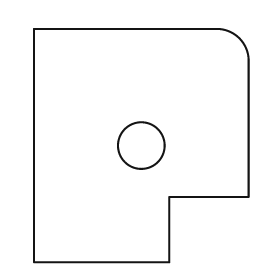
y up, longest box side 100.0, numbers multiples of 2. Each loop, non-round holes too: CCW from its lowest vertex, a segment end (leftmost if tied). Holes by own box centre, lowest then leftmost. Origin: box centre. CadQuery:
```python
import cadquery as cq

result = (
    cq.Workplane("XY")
    .moveTo(-46.0, -50.0)
    .lineTo(12.0, -50.0)
    .lineTo(12.0, -22.0)
    .lineTo(46.0, -22.0)
    .lineTo(46.0, 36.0)
    .threePointArc((42.0, 46.0), (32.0, 50.0))
    .lineTo(-46.0, 50.0)
    .close()
    .moveTo(0.0, 0.0)
    .circle(10.0)
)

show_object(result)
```